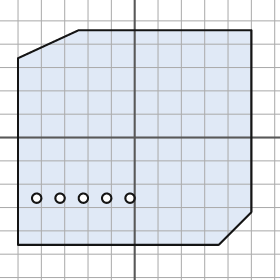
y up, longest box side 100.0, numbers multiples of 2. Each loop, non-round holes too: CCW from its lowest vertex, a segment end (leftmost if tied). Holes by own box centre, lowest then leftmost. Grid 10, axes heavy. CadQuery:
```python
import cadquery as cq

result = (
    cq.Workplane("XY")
    .moveTo(-50.0, -46.0)
    .lineTo(36.0, -46.0)
    .lineTo(50.0, -32.0)
    .lineTo(50.0, 46.0)
    .lineTo(-24.0, 46.0)
    .lineTo(-50.0, 34.0)
    .close()
    .moveTo(-42.0, -26.0)
    .circle(2.0)
    .moveTo(-32.0, -26.0)
    .circle(2.0)
    .moveTo(-22.0, -26.0)
    .circle(2.0)
    .moveTo(-12.0, -26.0)
    .circle(2.0)
    .moveTo(-2.0, -26.0)
    .circle(2.0)
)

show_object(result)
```